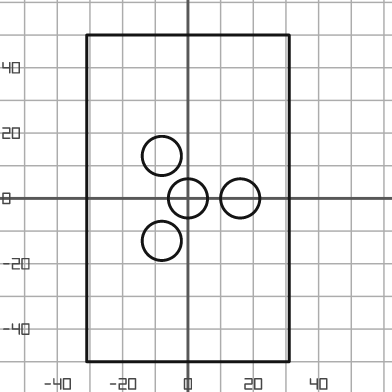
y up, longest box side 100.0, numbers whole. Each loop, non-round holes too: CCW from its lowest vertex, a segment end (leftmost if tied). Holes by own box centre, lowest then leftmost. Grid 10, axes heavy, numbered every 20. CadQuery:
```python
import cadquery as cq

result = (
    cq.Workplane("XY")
    .moveTo(-31.0, -50.0)
    .lineTo(31.0, -50.0)
    .lineTo(31.0, 50.0)
    .lineTo(-31.0, 50.0)
    .close()
    .moveTo(-8.0, -13.0)
    .circle(6.0)
    .moveTo(0.0, 0.0)
    .circle(6.0)
    .moveTo(16.0, 0.0)
    .circle(6.0)
    .moveTo(-8.0, 13.0)
    .circle(6.0)
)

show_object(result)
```